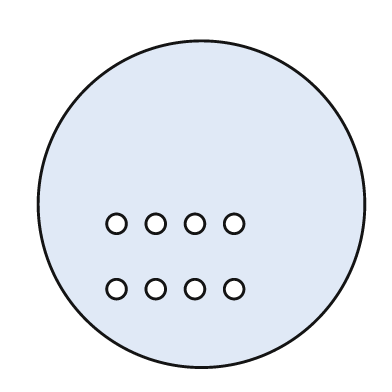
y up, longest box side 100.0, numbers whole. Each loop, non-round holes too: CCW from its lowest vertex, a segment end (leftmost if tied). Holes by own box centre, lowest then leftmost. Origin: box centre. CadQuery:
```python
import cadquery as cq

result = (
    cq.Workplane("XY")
    .moveTo(0.0, 0.0)
    .circle(50.0)
    .moveTo(-26.0, -26.0)
    .circle(3.0)
    .moveTo(-14.0, -26.0)
    .circle(3.0)
    .moveTo(-2.0, -26.0)
    .circle(3.0)
    .moveTo(10.0, -26.0)
    .circle(3.0)
    .moveTo(-26.0, -6.0)
    .circle(3.0)
    .moveTo(-14.0, -6.0)
    .circle(3.0)
    .moveTo(-2.0, -6.0)
    .circle(3.0)
    .moveTo(10.0, -6.0)
    .circle(3.0)
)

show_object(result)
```